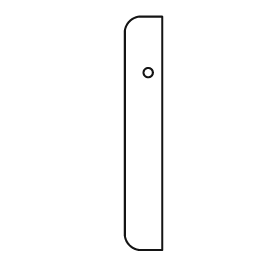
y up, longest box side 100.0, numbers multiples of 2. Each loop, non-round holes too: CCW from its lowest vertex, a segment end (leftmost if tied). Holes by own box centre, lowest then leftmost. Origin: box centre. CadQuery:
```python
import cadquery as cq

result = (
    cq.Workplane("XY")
    .moveTo(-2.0, -50.0)
    .lineTo(8.0, -50.0)
    .lineTo(8.0, 50.0)
    .lineTo(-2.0, 50.0)
    .threePointArc((-6.0, 48.0), (-8.0, 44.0))
    .lineTo(-8.0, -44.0)
    .threePointArc((-6.0, -48.0), (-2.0, -50.0))
    .close()
    .moveTo(2.0, 26.0)
    .circle(2.0)
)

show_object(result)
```